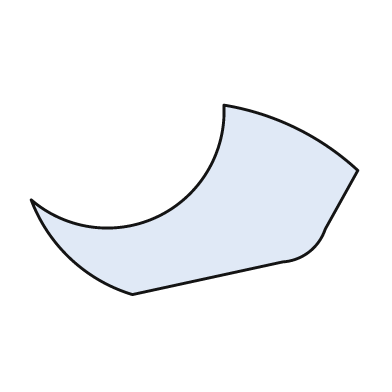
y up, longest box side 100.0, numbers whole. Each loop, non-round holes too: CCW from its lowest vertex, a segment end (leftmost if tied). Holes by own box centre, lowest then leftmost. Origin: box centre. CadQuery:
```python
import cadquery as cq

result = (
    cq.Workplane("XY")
    .moveTo(-19.0, -29.0)
    .lineTo(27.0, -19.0)
    .threePointArc((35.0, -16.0), (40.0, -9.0))
    .lineTo(50.0, 9.0)
    .threePointArc((31.0, 22.0), (9.0, 29.0))
    .threePointArc((-11.0, -5.0), (-50.0, 0.0))
    .threePointArc((-38.0, -18.0), (-19.0, -29.0))
    .close()
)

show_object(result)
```